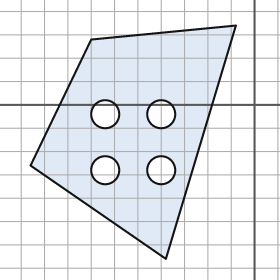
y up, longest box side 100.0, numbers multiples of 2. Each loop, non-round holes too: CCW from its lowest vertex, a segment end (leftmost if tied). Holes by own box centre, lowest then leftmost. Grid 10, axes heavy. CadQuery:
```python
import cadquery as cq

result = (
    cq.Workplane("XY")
    .moveTo(-38.0, -66.0)
    .lineTo(-8.0, 34.0)
    .lineTo(-70.0, 28.0)
    .lineTo(-96.0, -26.0)
    .close()
    .moveTo(-64.0, -28.0)
    .circle(6.0)
    .moveTo(-40.0, -28.0)
    .circle(6.0)
    .moveTo(-64.0, -4.0)
    .circle(6.0)
    .moveTo(-40.0, -4.0)
    .circle(6.0)
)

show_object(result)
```